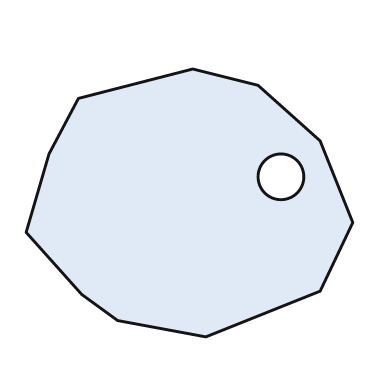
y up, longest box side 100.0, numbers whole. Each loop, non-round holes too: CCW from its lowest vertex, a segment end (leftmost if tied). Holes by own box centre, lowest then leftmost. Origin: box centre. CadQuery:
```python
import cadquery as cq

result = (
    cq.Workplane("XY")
    .moveTo(5.0, -41.0)
    .lineTo(40.0, -27.0)
    .lineTo(50.0, -6.0)
    .lineTo(40.0, 19.0)
    .lineTo(21.0, 36.0)
    .lineTo(1.0, 41.0)
    .lineTo(-34.0, 32.0)
    .lineTo(-43.0, 15.0)
    .lineTo(-50.0, -9.0)
    .lineTo(-33.0, -28.0)
    .lineTo(-22.0, -36.0)
    .close()
    .moveTo(28.0, 8.0)
    .circle(7.0)
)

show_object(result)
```